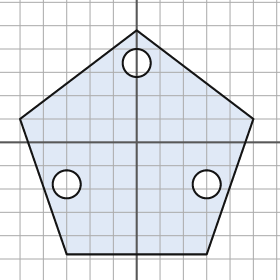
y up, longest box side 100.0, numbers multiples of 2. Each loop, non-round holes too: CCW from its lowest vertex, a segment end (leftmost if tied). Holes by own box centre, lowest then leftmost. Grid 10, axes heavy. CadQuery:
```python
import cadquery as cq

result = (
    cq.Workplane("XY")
    .moveTo(-30.0, -48.0)
    .lineTo(30.0, -48.0)
    .lineTo(50.0, 10.0)
    .lineTo(0.0, 48.0)
    .lineTo(-50.0, 10.0)
    .close()
    .moveTo(-30.0, -18.0)
    .circle(6.0)
    .moveTo(30.0, -18.0)
    .circle(6.0)
    .moveTo(0.0, 34.0)
    .circle(6.0)
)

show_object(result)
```